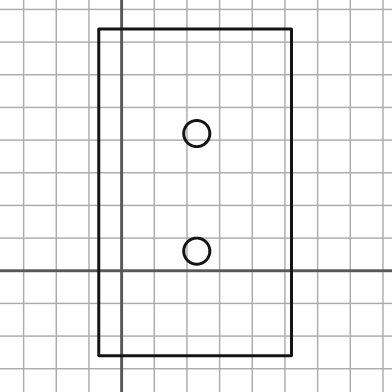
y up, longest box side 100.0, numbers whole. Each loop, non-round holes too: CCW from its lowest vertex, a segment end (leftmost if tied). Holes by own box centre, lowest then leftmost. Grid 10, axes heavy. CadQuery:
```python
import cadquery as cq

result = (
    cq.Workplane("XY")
    .moveTo(-7.0, -26.0)
    .lineTo(52.0, -26.0)
    .lineTo(52.0, 74.0)
    .lineTo(-7.0, 74.0)
    .close()
    .moveTo(23.0, 6.0)
    .circle(4.0)
    .moveTo(23.0, 42.0)
    .circle(4.0)
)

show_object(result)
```